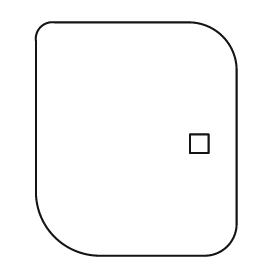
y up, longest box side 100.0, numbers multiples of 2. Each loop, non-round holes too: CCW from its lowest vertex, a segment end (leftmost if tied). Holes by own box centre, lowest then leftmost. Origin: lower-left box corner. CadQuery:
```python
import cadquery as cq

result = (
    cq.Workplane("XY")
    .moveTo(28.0, 0.0)
    .lineTo(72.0, 0.0)
    .threePointArc((82.0, 4.0), (86.0, 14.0))
    .lineTo(86.0, 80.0)
    .threePointArc((80.0, 94.0), (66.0, 100.0))
    .lineTo(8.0, 100.0)
    .threePointArc((2.0, 98.0), (0.0, 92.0))
    .lineTo(0.0, 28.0)
    .threePointArc((8.0, 8.0), (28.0, 0.0))
    .close()
    .moveTo(66.0, 44.0)
    .lineTo(74.0, 44.0)
    .lineTo(74.0, 52.0)
    .lineTo(66.0, 52.0)
    .close()
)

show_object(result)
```